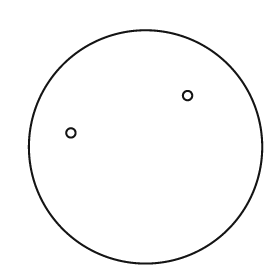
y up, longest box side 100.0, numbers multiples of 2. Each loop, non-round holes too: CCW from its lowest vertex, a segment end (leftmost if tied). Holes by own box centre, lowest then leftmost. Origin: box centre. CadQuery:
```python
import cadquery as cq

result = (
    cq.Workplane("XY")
    .moveTo(0.0, 0.0)
    .circle(50.0)
    .moveTo(-32.0, 6.0)
    .circle(2.0)
    .moveTo(18.0, 22.0)
    .circle(2.0)
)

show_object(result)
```